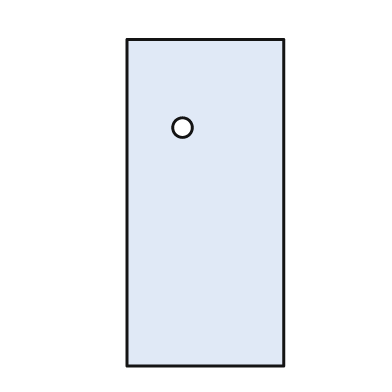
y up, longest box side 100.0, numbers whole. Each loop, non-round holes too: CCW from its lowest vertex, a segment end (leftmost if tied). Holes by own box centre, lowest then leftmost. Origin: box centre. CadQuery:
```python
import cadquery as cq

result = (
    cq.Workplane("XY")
    .moveTo(-24.0, -50.0)
    .lineTo(24.0, -50.0)
    .lineTo(24.0, 50.0)
    .lineTo(-24.0, 50.0)
    .close()
    .moveTo(-7.0, 23.0)
    .circle(3.0)
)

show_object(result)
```